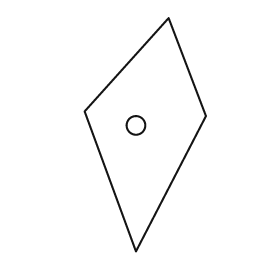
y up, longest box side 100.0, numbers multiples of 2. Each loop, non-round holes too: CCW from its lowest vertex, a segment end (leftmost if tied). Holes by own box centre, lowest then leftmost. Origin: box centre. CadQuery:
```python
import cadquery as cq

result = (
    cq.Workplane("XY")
    .moveTo(-4.0, -50.0)
    .lineTo(26.0, 8.0)
    .lineTo(10.0, 50.0)
    .lineTo(-26.0, 10.0)
    .close()
    .moveTo(-4.0, 4.0)
    .circle(4.0)
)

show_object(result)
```